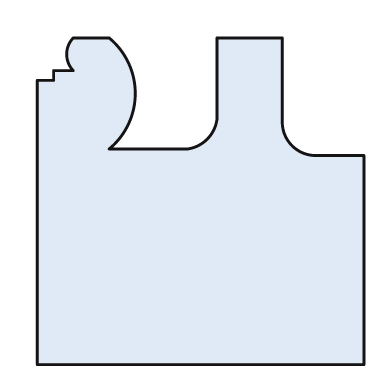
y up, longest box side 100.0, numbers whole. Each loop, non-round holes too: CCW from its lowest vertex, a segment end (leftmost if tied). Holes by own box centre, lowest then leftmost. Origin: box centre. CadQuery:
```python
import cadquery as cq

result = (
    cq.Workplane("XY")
    .moveTo(-50.0, -50.0)
    .lineTo(50.0, -50.0)
    .lineTo(50.0, 14.0)
    .lineTo(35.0, 14.0)
    .threePointArc((28.0, 17.0), (25.0, 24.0))
    .lineTo(25.0, 50.0)
    .lineTo(5.0, 50.0)
    .lineTo(5.0, 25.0)
    .threePointArc((2.0, 19.0), (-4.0, 16.0))
    .lineTo(-28.0, 16.0)
    .threePointArc((-20.0, 33.0), (-28.0, 50.0))
    .lineTo(-39.0, 50.0)
    .threePointArc((-41.0, 45.0), (-39.0, 40.0))
    .lineTo(-45.0, 40.0)
    .lineTo(-45.0, 37.0)
    .lineTo(-50.0, 37.0)
    .close()
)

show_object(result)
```